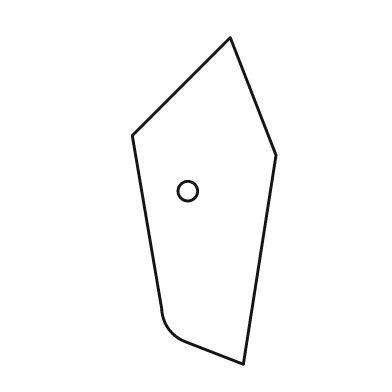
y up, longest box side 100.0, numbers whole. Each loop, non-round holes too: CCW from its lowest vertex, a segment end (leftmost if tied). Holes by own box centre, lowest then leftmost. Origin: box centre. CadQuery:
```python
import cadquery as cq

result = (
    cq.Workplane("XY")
    .moveTo(12.0, -50.0)
    .lineTo(22.0, 14.0)
    .lineTo(8.0, 50.0)
    .lineTo(-22.0, 20.0)
    .lineTo(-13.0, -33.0)
    .threePointArc((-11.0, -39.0), (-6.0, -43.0))
    .close()
    .moveTo(-5.0, 3.0)
    .circle(3.0)
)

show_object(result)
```